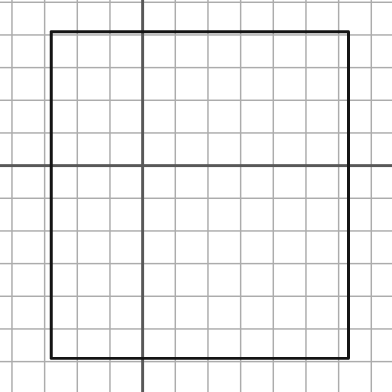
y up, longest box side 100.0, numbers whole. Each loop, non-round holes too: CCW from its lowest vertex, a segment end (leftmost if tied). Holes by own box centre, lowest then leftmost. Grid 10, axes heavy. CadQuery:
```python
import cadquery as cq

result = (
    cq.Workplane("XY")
    .moveTo(-28.0, -59.0)
    .lineTo(63.0, -59.0)
    .lineTo(63.0, 41.0)
    .lineTo(-28.0, 41.0)
    .close()
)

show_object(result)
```